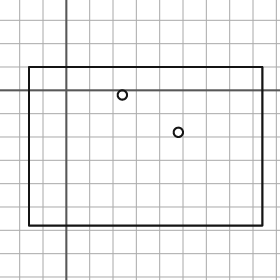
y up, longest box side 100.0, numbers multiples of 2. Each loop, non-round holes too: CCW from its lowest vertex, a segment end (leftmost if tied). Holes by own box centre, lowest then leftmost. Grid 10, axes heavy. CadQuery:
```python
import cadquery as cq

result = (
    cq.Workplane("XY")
    .moveTo(-16.0, -58.0)
    .lineTo(84.0, -58.0)
    .lineTo(84.0, 10.0)
    .lineTo(-16.0, 10.0)
    .close()
    .moveTo(48.0, -18.0)
    .circle(2.0)
    .moveTo(24.0, -2.0)
    .circle(2.0)
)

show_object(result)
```